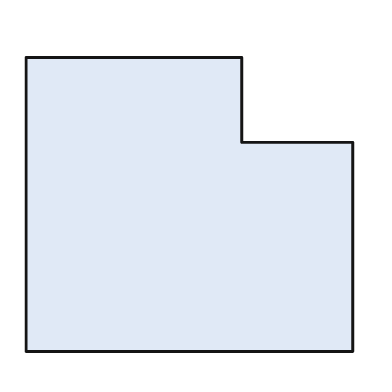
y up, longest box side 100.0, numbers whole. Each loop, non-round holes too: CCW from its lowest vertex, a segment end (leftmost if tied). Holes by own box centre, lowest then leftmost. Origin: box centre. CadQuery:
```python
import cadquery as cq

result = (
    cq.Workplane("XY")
    .moveTo(-50.0, -45.0)
    .lineTo(50.0, -45.0)
    .lineTo(50.0, 19.0)
    .lineTo(16.0, 19.0)
    .lineTo(16.0, 45.0)
    .lineTo(-50.0, 45.0)
    .close()
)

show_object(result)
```